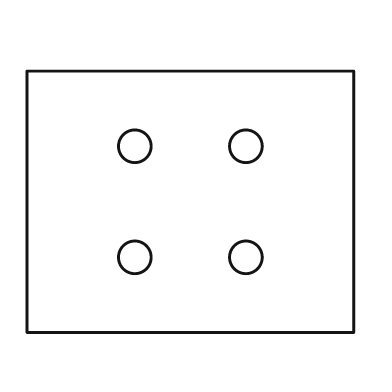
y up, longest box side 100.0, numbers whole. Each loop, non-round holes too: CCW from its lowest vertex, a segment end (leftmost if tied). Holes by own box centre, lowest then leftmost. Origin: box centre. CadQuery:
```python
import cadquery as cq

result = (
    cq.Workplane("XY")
    .moveTo(-50.0, -40.0)
    .lineTo(50.0, -40.0)
    .lineTo(50.0, 40.0)
    .lineTo(-50.0, 40.0)
    .close()
    .moveTo(-17.0, -17.0)
    .circle(5.0)
    .moveTo(17.0, -17.0)
    .circle(5.0)
    .moveTo(-17.0, 17.0)
    .circle(5.0)
    .moveTo(17.0, 17.0)
    .circle(5.0)
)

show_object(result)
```